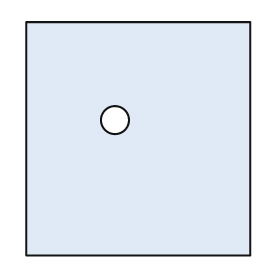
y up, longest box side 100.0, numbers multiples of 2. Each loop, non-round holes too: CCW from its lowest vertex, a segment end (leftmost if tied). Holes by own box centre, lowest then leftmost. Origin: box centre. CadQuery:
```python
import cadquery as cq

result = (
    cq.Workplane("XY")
    .moveTo(-48.0, -50.0)
    .lineTo(48.0, -50.0)
    .lineTo(48.0, 50.0)
    .lineTo(-48.0, 50.0)
    .close()
    .moveTo(-10.0, 8.0)
    .circle(6.0)
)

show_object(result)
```